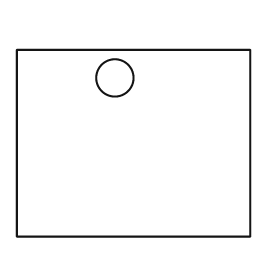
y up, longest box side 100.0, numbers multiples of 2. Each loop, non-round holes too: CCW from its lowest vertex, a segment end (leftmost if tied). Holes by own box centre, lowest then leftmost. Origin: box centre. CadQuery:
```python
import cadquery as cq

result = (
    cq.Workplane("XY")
    .moveTo(-50.0, -40.0)
    .lineTo(50.0, -40.0)
    .lineTo(50.0, 40.0)
    .lineTo(-50.0, 40.0)
    .close()
    .moveTo(-8.0, 28.0)
    .circle(8.0)
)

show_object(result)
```